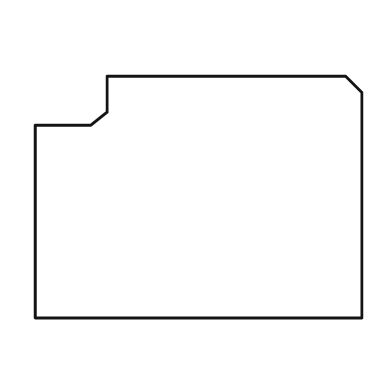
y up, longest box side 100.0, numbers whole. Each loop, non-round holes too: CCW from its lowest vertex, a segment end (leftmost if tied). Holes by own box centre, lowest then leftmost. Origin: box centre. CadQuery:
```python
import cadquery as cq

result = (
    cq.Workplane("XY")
    .moveTo(-50.0, -37.0)
    .lineTo(50.0, -37.0)
    .lineTo(50.0, 32.0)
    .lineTo(45.0, 37.0)
    .lineTo(-28.0, 37.0)
    .lineTo(-28.0, 26.0)
    .lineTo(-33.0, 22.0)
    .lineTo(-50.0, 22.0)
    .close()
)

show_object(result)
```